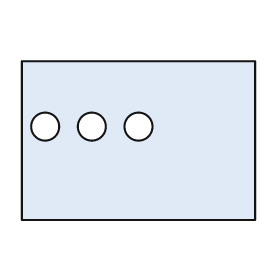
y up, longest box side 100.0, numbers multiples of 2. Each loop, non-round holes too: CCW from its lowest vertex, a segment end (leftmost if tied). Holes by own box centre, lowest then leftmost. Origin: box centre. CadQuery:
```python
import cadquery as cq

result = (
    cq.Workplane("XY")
    .moveTo(-50.0, -34.0)
    .lineTo(50.0, -34.0)
    .lineTo(50.0, 34.0)
    .lineTo(-50.0, 34.0)
    .close()
    .moveTo(-40.0, 6.0)
    .circle(6.0)
    .moveTo(-20.0, 6.0)
    .circle(6.0)
    .moveTo(0.0, 6.0)
    .circle(6.0)
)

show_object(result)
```